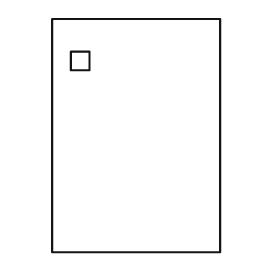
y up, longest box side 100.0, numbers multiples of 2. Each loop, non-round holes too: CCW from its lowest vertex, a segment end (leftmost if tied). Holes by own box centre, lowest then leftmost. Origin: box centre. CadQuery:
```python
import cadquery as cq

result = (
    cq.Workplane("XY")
    .moveTo(-36.0, -50.0)
    .lineTo(36.0, -50.0)
    .lineTo(36.0, 50.0)
    .lineTo(-36.0, 50.0)
    .close()
    .moveTo(-28.0, 28.0)
    .lineTo(-20.0, 28.0)
    .lineTo(-20.0, 36.0)
    .lineTo(-28.0, 36.0)
    .close()
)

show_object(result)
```